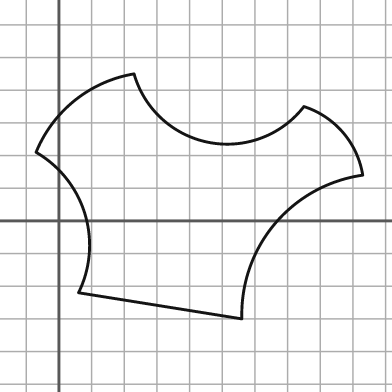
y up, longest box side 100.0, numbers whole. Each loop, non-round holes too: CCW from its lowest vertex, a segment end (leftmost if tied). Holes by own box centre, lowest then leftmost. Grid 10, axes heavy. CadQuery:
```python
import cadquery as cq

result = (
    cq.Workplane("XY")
    .moveTo(56.0, -30.0)
    .threePointArc((66.0, -1.0), (93.0, 14.0))
    .threePointArc((87.0, 27.0), (75.0, 35.0))
    .threePointArc((46.0, 24.0), (23.0, 45.0))
    .threePointArc((5.0, 37.0), (-7.0, 21.0))
    .threePointArc((8.0, 2.0), (6.0, -22.0))
    .close()
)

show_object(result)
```